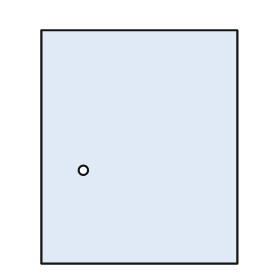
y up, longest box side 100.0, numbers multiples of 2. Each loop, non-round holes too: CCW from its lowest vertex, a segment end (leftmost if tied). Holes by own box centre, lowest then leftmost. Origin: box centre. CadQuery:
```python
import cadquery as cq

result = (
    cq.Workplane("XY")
    .moveTo(-42.0, -50.0)
    .lineTo(42.0, -50.0)
    .lineTo(42.0, 50.0)
    .lineTo(-42.0, 50.0)
    .close()
    .moveTo(-24.0, -10.0)
    .circle(2.0)
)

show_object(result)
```